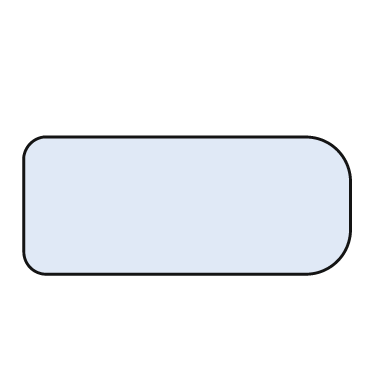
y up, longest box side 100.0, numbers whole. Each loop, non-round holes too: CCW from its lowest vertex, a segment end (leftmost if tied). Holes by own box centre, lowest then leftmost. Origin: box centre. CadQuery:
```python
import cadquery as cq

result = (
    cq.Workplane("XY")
    .moveTo(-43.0, -21.0)
    .lineTo(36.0, -21.0)
    .threePointArc((46.0, -17.0), (50.0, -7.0))
    .lineTo(50.0, 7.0)
    .threePointArc((46.0, 17.0), (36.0, 21.0))
    .lineTo(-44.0, 21.0)
    .threePointArc((-48.0, 19.0), (-50.0, 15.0))
    .lineTo(-50.0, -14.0)
    .threePointArc((-48.0, -19.0), (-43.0, -21.0))
    .close()
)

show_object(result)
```